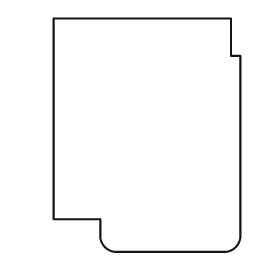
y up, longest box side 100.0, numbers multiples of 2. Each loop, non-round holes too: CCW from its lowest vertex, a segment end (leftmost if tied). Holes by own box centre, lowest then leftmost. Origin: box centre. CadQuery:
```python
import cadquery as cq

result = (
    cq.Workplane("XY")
    .moveTo(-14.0, -50.0)
    .lineTo(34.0, -50.0)
    .threePointArc((38.0, -48.0), (40.0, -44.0))
    .lineTo(40.0, 34.0)
    .lineTo(36.0, 34.0)
    .lineTo(36.0, 50.0)
    .lineTo(-40.0, 50.0)
    .lineTo(-40.0, -36.0)
    .lineTo(-20.0, -36.0)
    .lineTo(-20.0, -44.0)
    .threePointArc((-18.0, -48.0), (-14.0, -50.0))
    .close()
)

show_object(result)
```